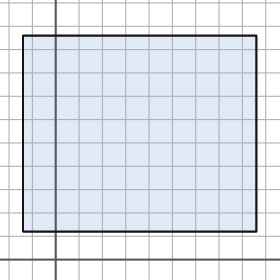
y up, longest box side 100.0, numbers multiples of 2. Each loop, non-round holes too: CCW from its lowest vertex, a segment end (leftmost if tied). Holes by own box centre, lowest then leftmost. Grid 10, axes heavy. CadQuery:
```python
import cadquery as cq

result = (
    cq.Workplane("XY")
    .moveTo(-14.0, 12.0)
    .lineTo(86.0, 12.0)
    .lineTo(86.0, 96.0)
    .lineTo(-14.0, 96.0)
    .close()
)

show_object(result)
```